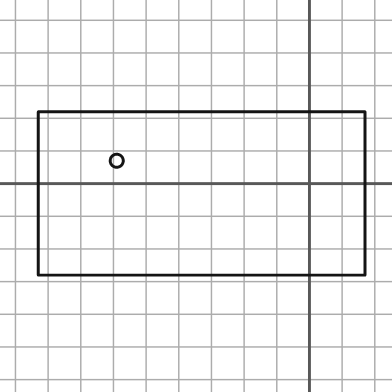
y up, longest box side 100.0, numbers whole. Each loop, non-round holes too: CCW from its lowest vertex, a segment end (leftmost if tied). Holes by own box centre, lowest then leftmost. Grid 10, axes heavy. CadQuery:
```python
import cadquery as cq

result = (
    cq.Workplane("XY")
    .moveTo(-83.0, -28.0)
    .lineTo(17.0, -28.0)
    .lineTo(17.0, 22.0)
    .lineTo(-83.0, 22.0)
    .close()
    .moveTo(-59.0, 7.0)
    .circle(2.0)
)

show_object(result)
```